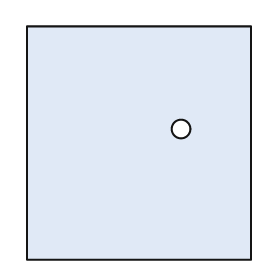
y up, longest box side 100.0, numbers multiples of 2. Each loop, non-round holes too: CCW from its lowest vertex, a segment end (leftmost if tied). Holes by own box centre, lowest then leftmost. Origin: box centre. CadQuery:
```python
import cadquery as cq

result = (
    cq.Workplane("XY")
    .moveTo(-48.0, -50.0)
    .lineTo(48.0, -50.0)
    .lineTo(48.0, 50.0)
    .lineTo(-48.0, 50.0)
    .close()
    .moveTo(18.0, 6.0)
    .circle(4.0)
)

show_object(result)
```